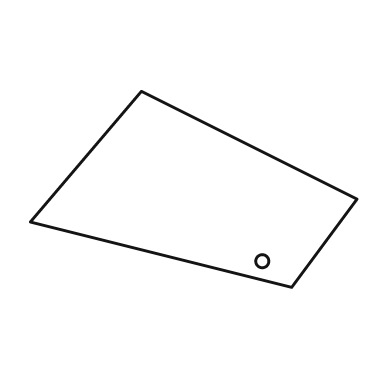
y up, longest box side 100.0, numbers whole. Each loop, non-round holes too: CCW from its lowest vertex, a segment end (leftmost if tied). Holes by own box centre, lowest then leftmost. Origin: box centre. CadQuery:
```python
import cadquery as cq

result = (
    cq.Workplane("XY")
    .moveTo(30.0, -30.0)
    .lineTo(50.0, -3.0)
    .lineTo(-16.0, 30.0)
    .lineTo(-50.0, -10.0)
    .close()
    .moveTo(21.0, -22.0)
    .circle(2.0)
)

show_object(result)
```